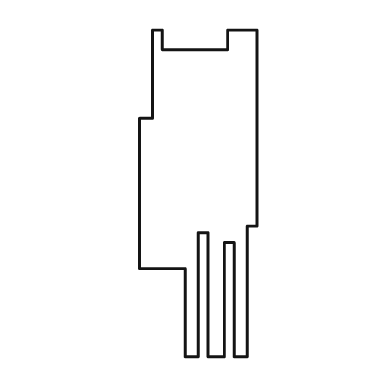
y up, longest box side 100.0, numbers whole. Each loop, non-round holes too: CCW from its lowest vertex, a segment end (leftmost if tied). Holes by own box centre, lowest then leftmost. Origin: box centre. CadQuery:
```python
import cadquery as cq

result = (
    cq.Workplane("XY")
    .moveTo(-4.0, -50.0)
    .lineTo(0.0, -50.0)
    .lineTo(0.0, -12.0)
    .lineTo(3.0, -12.0)
    .lineTo(3.0, -50.0)
    .lineTo(8.0, -50.0)
    .lineTo(8.0, -15.0)
    .lineTo(11.0, -15.0)
    .lineTo(11.0, -50.0)
    .lineTo(15.0, -50.0)
    .lineTo(15.0, -10.0)
    .lineTo(18.0, -10.0)
    .lineTo(18.0, 50.0)
    .lineTo(9.0, 50.0)
    .lineTo(9.0, 44.0)
    .lineTo(-11.0, 44.0)
    .lineTo(-11.0, 50.0)
    .lineTo(-14.0, 50.0)
    .lineTo(-14.0, 23.0)
    .lineTo(-18.0, 23.0)
    .lineTo(-18.0, -23.0)
    .lineTo(-4.0, -23.0)
    .close()
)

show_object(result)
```